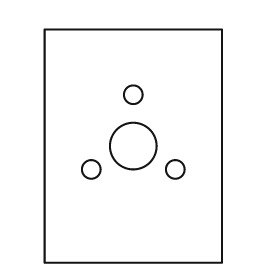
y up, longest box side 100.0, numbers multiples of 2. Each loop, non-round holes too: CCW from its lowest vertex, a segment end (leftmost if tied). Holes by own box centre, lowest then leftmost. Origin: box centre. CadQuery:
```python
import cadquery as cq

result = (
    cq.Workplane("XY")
    .moveTo(-38.0, -50.0)
    .lineTo(38.0, -50.0)
    .lineTo(38.0, 50.0)
    .lineTo(-38.0, 50.0)
    .close()
    .moveTo(-18.0, -10.0)
    .circle(4.0)
    .moveTo(18.0, -10.0)
    .circle(4.0)
    .moveTo(0.0, 0.0)
    .circle(10.0)
    .moveTo(0.0, 22.0)
    .circle(4.0)
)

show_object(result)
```